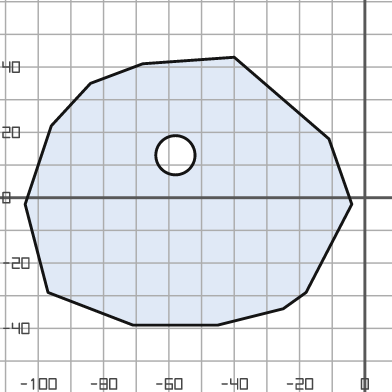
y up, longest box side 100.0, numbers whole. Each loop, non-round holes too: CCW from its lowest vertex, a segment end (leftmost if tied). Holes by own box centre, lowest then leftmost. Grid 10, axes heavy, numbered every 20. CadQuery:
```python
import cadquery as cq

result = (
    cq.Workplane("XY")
    .moveTo(-71.0, -39.0)
    .lineTo(-45.0, -39.0)
    .lineTo(-25.0, -34.0)
    .lineTo(-18.0, -29.0)
    .lineTo(-4.0, -2.0)
    .lineTo(-11.0, 18.0)
    .lineTo(-40.0, 43.0)
    .lineTo(-68.0, 41.0)
    .lineTo(-84.0, 35.0)
    .lineTo(-96.0, 22.0)
    .lineTo(-104.0, -2.0)
    .lineTo(-97.0, -29.0)
    .close()
    .moveTo(-58.0, 13.0)
    .circle(6.0)
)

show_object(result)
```